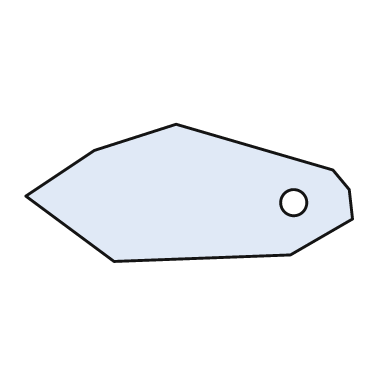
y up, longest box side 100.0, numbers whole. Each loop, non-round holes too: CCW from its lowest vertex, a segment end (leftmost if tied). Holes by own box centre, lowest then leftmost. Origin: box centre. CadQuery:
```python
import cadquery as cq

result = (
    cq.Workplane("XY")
    .moveTo(-23.0, -21.0)
    .lineTo(31.0, -19.0)
    .lineTo(50.0, -8.0)
    .lineTo(49.0, 1.0)
    .lineTo(44.0, 7.0)
    .lineTo(-4.0, 21.0)
    .lineTo(-29.0, 13.0)
    .lineTo(-50.0, -1.0)
    .close()
    .moveTo(32.0, -3.0)
    .circle(4.0)
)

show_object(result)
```